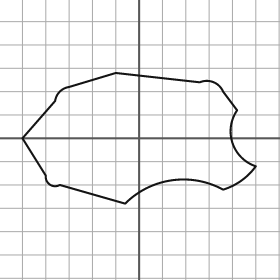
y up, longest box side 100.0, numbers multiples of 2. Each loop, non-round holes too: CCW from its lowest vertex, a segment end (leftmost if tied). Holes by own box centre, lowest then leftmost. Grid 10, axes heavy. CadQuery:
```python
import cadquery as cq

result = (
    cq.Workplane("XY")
    .moveTo(-6.0, -28.0)
    .threePointArc((14.0, -18.0), (36.0, -22.0))
    .threePointArc((44.0, -18.0), (50.0, -12.0))
    .threePointArc((40.0, -2.0), (42.0, 12.0))
    .lineTo(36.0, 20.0)
    .threePointArc((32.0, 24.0), (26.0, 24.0))
    .lineTo(-10.0, 28.0)
    .lineTo(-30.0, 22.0)
    .threePointArc((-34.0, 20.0), (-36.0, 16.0))
    .lineTo(-50.0, 0.0)
    .lineTo(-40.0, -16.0)
    .threePointArc((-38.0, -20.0), (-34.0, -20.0))
    .close()
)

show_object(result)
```